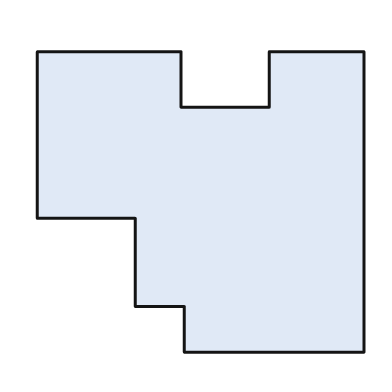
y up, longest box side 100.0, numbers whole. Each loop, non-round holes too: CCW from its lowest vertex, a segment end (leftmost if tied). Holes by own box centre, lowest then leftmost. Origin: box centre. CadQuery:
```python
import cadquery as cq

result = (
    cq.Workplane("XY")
    .moveTo(-5.0, -46.0)
    .lineTo(50.0, -46.0)
    .lineTo(50.0, 46.0)
    .lineTo(21.0, 46.0)
    .lineTo(21.0, 29.0)
    .lineTo(-6.0, 29.0)
    .lineTo(-6.0, 46.0)
    .lineTo(-50.0, 46.0)
    .lineTo(-50.0, -5.0)
    .lineTo(-20.0, -5.0)
    .lineTo(-20.0, -32.0)
    .lineTo(-5.0, -32.0)
    .close()
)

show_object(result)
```